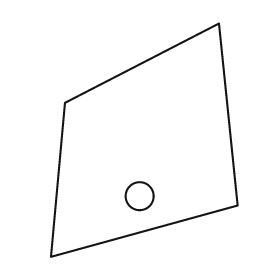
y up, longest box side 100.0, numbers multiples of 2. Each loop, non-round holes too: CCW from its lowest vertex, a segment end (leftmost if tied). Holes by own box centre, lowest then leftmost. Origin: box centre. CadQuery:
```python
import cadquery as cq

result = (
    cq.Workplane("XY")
    .moveTo(-40.0, -50.0)
    .lineTo(40.0, -28.0)
    .lineTo(32.0, 50.0)
    .lineTo(-34.0, 16.0)
    .close()
    .moveTo(-2.0, -24.0)
    .circle(6.0)
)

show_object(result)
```